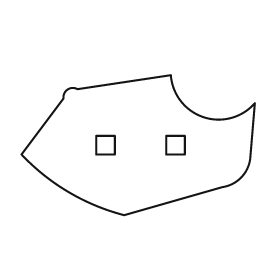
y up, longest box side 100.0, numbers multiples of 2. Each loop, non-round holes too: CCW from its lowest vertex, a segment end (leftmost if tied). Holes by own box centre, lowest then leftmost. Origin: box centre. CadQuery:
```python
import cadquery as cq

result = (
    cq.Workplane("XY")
    .moveTo(-6.0, -30.0)
    .lineTo(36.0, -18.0)
    .threePointArc((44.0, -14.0), (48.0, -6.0))
    .lineTo(50.0, 18.0)
    .threePointArc((28.0, 12.0), (14.0, 30.0))
    .lineTo(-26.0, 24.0)
    .threePointArc((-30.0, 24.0), (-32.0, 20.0))
    .lineTo(-50.0, -4.0)
    .threePointArc((-30.0, -20.0), (-6.0, -30.0))
    .close()
    .moveTo(-18.0, -4.0)
    .lineTo(-10.0, -4.0)
    .lineTo(-10.0, 4.0)
    .lineTo(-18.0, 4.0)
    .close()
    .moveTo(12.0, -4.0)
    .lineTo(20.0, -4.0)
    .lineTo(20.0, 4.0)
    .lineTo(12.0, 4.0)
    .close()
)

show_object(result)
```